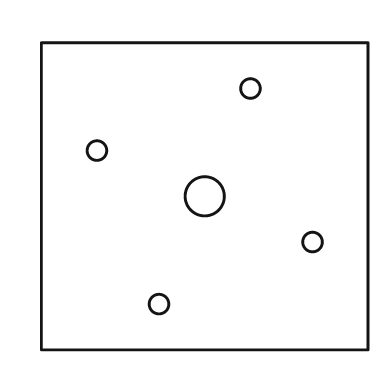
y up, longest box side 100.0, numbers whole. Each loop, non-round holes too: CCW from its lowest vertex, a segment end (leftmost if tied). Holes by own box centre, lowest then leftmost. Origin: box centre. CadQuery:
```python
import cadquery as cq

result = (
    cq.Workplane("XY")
    .moveTo(-50.0, -47.0)
    .lineTo(50.0, -47.0)
    .lineTo(50.0, 47.0)
    .lineTo(-50.0, 47.0)
    .close()
    .moveTo(-14.0, -33.0)
    .circle(3.0)
    .moveTo(33.0, -14.0)
    .circle(3.0)
    .moveTo(0.0, 0.0)
    .circle(6.0)
    .moveTo(-33.0, 14.0)
    .circle(3.0)
    .moveTo(14.0, 33.0)
    .circle(3.0)
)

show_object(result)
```